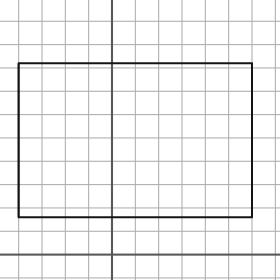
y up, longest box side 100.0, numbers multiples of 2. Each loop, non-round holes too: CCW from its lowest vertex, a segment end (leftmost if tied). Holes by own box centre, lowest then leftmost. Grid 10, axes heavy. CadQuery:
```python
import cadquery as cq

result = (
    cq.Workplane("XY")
    .moveTo(-40.0, 16.0)
    .lineTo(60.0, 16.0)
    .lineTo(60.0, 82.0)
    .lineTo(-40.0, 82.0)
    .close()
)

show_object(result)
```